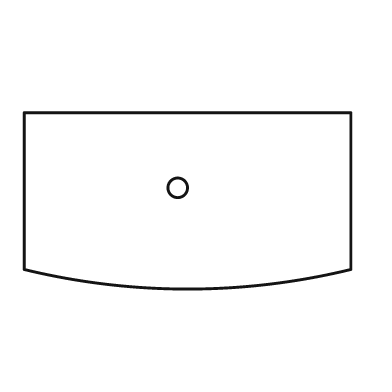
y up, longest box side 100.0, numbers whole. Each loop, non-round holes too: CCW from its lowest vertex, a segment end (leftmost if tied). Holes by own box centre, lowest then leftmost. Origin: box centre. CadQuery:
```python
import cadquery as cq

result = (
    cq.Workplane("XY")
    .moveTo(-50.0, -21.0)
    .threePointArc((0.0, -27.0), (50.0, -21.0))
    .lineTo(50.0, 27.0)
    .lineTo(-50.0, 27.0)
    .close()
    .moveTo(-3.0, 4.0)
    .circle(3.0)
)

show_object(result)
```